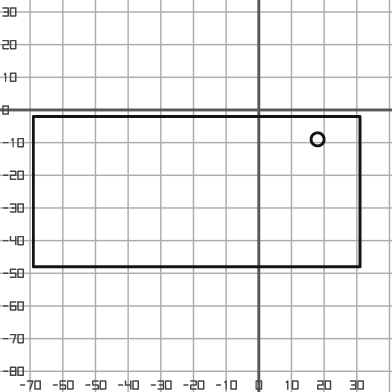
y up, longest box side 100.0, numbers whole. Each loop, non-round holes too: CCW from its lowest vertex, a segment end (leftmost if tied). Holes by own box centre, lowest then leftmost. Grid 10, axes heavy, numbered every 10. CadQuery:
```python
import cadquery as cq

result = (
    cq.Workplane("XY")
    .moveTo(-69.0, -48.0)
    .lineTo(31.0, -48.0)
    .lineTo(31.0, -2.0)
    .lineTo(-69.0, -2.0)
    .close()
    .moveTo(18.0, -9.0)
    .circle(2.0)
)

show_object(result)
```